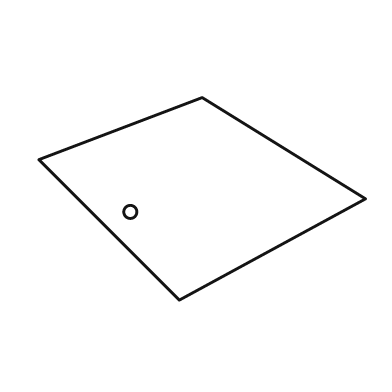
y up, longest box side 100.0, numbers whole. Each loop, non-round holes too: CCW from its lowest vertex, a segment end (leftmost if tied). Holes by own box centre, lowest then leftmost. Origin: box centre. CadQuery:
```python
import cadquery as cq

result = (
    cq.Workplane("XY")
    .moveTo(-7.0, -31.0)
    .lineTo(50.0, 0.0)
    .lineTo(0.0, 31.0)
    .lineTo(-50.0, 12.0)
    .close()
    .moveTo(-22.0, -4.0)
    .circle(2.0)
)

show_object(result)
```